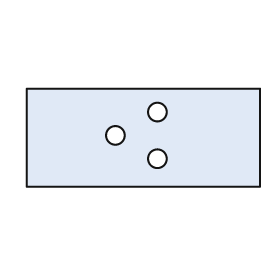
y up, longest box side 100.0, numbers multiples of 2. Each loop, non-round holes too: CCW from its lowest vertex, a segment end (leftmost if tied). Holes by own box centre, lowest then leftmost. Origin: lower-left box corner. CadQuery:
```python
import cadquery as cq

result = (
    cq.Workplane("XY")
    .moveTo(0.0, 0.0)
    .lineTo(100.0, 0.0)
    .lineTo(100.0, 42.0)
    .lineTo(0.0, 42.0)
    .close()
    .moveTo(56.0, 12.0)
    .circle(4.0)
    .moveTo(38.0, 22.0)
    .circle(4.0)
    .moveTo(56.0, 32.0)
    .circle(4.0)
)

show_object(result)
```